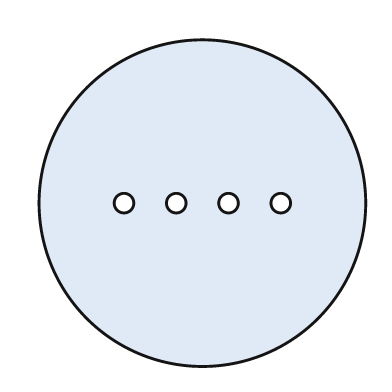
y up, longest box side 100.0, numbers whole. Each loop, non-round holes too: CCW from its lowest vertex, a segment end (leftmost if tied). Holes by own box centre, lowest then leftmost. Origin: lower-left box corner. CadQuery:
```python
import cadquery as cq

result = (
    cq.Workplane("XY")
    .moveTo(50.0, 50.0)
    .circle(50.0)
    .moveTo(26.0, 50.0)
    .circle(3.0)
    .moveTo(42.0, 50.0)
    .circle(3.0)
    .moveTo(58.0, 50.0)
    .circle(3.0)
    .moveTo(74.0, 50.0)
    .circle(3.0)
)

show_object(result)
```